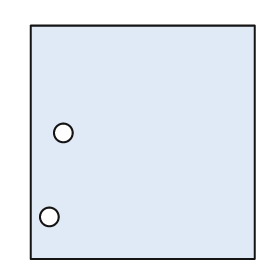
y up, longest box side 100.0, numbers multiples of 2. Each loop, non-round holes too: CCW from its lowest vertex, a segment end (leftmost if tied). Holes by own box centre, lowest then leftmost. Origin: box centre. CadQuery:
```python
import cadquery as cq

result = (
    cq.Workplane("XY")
    .moveTo(-48.0, -50.0)
    .lineTo(48.0, -50.0)
    .lineTo(48.0, 50.0)
    .lineTo(-48.0, 50.0)
    .close()
    .moveTo(-40.0, -32.0)
    .circle(4.0)
    .moveTo(-34.0, 4.0)
    .circle(4.0)
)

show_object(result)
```